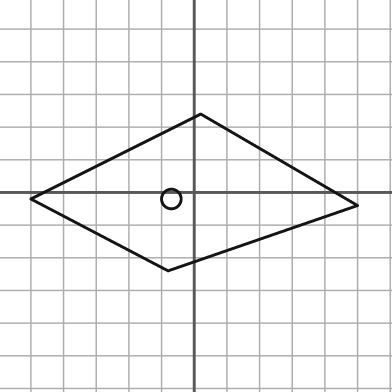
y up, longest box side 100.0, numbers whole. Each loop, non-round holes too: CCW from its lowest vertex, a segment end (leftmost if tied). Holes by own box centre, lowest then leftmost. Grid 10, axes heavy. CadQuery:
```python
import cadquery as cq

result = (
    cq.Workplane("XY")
    .moveTo(-8.0, -24.0)
    .lineTo(50.0, -4.0)
    .lineTo(2.0, 24.0)
    .lineTo(-50.0, -2.0)
    .close()
    .moveTo(-7.0, -2.0)
    .circle(3.0)
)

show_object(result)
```